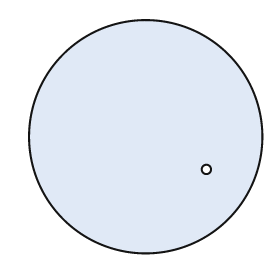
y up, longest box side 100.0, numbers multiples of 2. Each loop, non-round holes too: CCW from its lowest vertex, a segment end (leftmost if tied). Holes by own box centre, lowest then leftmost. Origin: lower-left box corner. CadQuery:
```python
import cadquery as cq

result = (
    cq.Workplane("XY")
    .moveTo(50.0, 50.0)
    .circle(50.0)
    .moveTo(76.0, 36.0)
    .circle(2.0)
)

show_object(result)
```